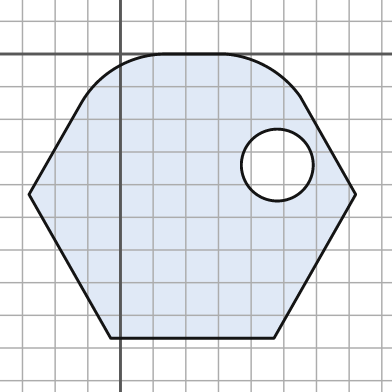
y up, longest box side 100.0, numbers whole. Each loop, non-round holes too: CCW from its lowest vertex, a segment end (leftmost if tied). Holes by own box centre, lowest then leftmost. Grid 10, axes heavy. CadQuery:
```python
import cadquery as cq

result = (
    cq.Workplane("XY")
    .moveTo(-3.0, -87.0)
    .lineTo(47.0, -87.0)
    .lineTo(72.0, -43.0)
    .lineTo(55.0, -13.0)
    .threePointArc((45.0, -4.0), (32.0, 0.0))
    .lineTo(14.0, 0.0)
    .threePointArc((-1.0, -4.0), (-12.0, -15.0))
    .lineTo(-28.0, -43.0)
    .close()
    .moveTo(48.0, -34.0)
    .circle(11.0)
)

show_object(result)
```